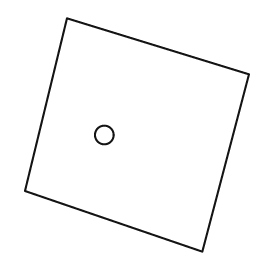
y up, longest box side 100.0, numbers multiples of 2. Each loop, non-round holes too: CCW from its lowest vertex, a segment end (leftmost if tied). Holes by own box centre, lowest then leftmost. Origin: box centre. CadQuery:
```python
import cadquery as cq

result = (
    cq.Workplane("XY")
    .moveTo(28.0, -50.0)
    .lineTo(48.0, 26.0)
    .lineTo(-30.0, 50.0)
    .lineTo(-48.0, -24.0)
    .close()
    .moveTo(-14.0, 0.0)
    .circle(4.0)
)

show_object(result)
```